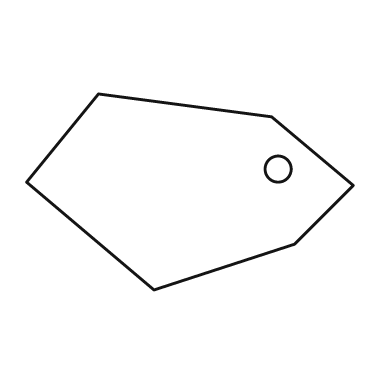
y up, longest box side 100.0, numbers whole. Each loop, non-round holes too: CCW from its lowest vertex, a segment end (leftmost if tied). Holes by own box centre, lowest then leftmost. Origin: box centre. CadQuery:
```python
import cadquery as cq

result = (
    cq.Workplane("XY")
    .moveTo(-11.0, -30.0)
    .lineTo(32.0, -16.0)
    .lineTo(50.0, 2.0)
    .lineTo(25.0, 23.0)
    .lineTo(-28.0, 30.0)
    .lineTo(-50.0, 3.0)
    .close()
    .moveTo(27.0, 7.0)
    .circle(4.0)
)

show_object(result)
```